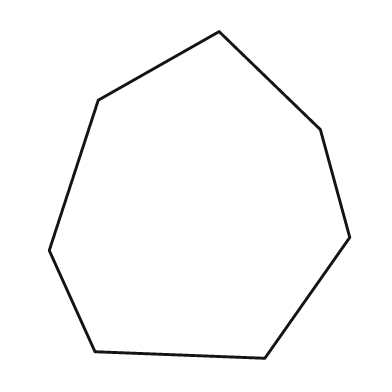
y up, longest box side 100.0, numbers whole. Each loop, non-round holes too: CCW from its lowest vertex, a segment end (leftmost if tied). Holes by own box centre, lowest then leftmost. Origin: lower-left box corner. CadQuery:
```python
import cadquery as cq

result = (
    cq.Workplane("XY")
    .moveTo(66.0, 0.0)
    .lineTo(92.0, 37.0)
    .lineTo(83.0, 70.0)
    .lineTo(52.0, 100.0)
    .lineTo(15.0, 79.0)
    .lineTo(0.0, 33.0)
    .lineTo(14.0, 2.0)
    .close()
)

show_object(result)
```